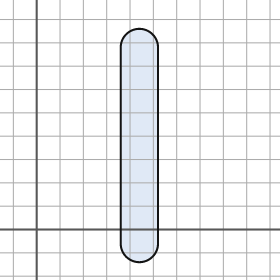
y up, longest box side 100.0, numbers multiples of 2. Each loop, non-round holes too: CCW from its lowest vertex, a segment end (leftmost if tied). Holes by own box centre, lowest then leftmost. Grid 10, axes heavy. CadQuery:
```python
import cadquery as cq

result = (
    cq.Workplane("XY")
    .moveTo(36.0, -6.0)
    .threePointArc((44.0, -14.0), (52.0, -6.0))
    .lineTo(52.0, 78.0)
    .threePointArc((44.0, 86.0), (36.0, 78.0))
    .close()
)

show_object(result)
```